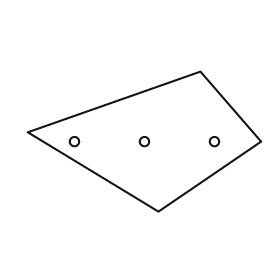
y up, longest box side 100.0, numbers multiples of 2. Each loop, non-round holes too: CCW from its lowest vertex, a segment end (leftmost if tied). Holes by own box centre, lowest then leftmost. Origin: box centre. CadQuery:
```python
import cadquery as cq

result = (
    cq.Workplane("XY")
    .moveTo(6.0, -30.0)
    .lineTo(50.0, 0.0)
    .lineTo(24.0, 30.0)
    .lineTo(-50.0, 4.0)
    .close()
    .moveTo(-30.0, 0.0)
    .circle(2.0)
    .moveTo(0.0, 0.0)
    .circle(2.0)
    .moveTo(30.0, 0.0)
    .circle(2.0)
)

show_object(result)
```